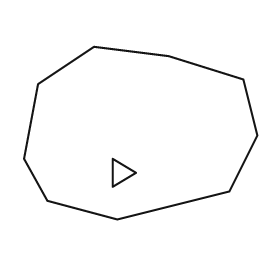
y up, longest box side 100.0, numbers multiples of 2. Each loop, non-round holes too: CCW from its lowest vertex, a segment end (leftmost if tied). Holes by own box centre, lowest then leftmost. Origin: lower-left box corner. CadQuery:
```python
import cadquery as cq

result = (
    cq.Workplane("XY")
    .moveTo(40.0, 0.0)
    .lineTo(88.0, 12.0)
    .lineTo(100.0, 36.0)
    .lineTo(94.0, 60.0)
    .lineTo(62.0, 70.0)
    .lineTo(30.0, 74.0)
    .lineTo(6.0, 58.0)
    .lineTo(0.0, 26.0)
    .lineTo(10.0, 8.0)
    .close()
    .moveTo(38.0, 14.0)
    .lineTo(48.0, 20.0)
    .lineTo(38.0, 26.0)
    .close()
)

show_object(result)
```